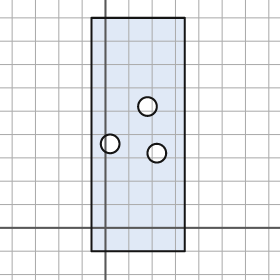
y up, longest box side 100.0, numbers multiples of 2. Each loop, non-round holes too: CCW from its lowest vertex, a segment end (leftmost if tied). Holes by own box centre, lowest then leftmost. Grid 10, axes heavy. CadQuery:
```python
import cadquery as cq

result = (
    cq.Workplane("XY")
    .moveTo(-6.0, -10.0)
    .lineTo(34.0, -10.0)
    .lineTo(34.0, 90.0)
    .lineTo(-6.0, 90.0)
    .close()
    .moveTo(22.0, 32.0)
    .circle(4.0)
    .moveTo(2.0, 36.0)
    .circle(4.0)
    .moveTo(18.0, 52.0)
    .circle(4.0)
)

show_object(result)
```